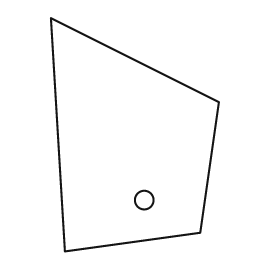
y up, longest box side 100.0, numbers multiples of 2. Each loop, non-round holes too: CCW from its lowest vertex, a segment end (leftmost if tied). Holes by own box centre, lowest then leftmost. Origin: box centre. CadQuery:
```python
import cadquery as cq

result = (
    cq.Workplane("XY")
    .moveTo(-30.0, -50.0)
    .lineTo(28.0, -42.0)
    .lineTo(36.0, 14.0)
    .lineTo(-36.0, 50.0)
    .close()
    .moveTo(4.0, -28.0)
    .circle(4.0)
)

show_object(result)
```